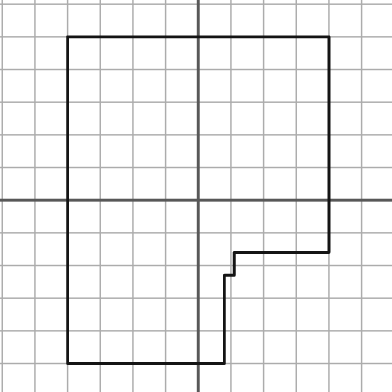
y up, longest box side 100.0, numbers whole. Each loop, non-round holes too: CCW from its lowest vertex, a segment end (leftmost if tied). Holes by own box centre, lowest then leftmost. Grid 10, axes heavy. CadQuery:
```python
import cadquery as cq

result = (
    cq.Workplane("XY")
    .moveTo(-40.0, -50.0)
    .lineTo(8.0, -50.0)
    .lineTo(8.0, -23.0)
    .lineTo(11.0, -23.0)
    .lineTo(11.0, -16.0)
    .lineTo(40.0, -16.0)
    .lineTo(40.0, 50.0)
    .lineTo(-40.0, 50.0)
    .close()
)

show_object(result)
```